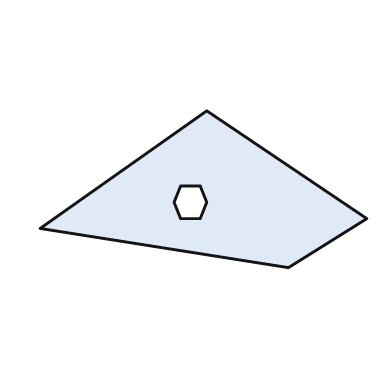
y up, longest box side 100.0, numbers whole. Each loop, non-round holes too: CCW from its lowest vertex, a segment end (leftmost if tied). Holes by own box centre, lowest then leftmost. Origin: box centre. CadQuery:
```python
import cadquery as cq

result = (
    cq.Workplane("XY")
    .moveTo(26.0, -24.0)
    .lineTo(50.0, -9.0)
    .lineTo(1.0, 24.0)
    .lineTo(-50.0, -12.0)
    .close()
    .moveTo(-7.0, -9.0)
    .lineTo(-1.0, -9.0)
    .lineTo(1.0, -4.0)
    .lineTo(-1.0, 1.0)
    .lineTo(-7.0, 1.0)
    .lineTo(-9.0, -4.0)
    .close()
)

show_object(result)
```